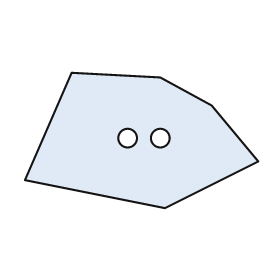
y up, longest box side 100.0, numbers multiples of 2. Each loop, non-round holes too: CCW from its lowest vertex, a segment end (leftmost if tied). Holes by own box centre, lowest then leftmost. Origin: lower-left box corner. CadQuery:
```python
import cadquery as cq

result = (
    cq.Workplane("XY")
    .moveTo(60.0, 0.0)
    .lineTo(100.0, 20.0)
    .lineTo(80.0, 44.0)
    .lineTo(58.0, 56.0)
    .lineTo(20.0, 58.0)
    .lineTo(0.0, 12.0)
    .close()
    .moveTo(44.0, 30.0)
    .circle(4.0)
    .moveTo(58.0, 30.0)
    .circle(4.0)
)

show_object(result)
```